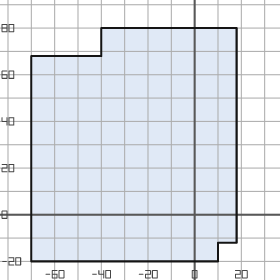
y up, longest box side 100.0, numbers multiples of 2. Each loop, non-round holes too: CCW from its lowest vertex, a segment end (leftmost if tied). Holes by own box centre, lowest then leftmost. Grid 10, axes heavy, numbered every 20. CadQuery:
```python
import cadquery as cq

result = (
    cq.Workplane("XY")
    .moveTo(-70.0, -20.0)
    .lineTo(10.0, -20.0)
    .lineTo(10.0, -12.0)
    .lineTo(18.0, -12.0)
    .lineTo(18.0, 80.0)
    .lineTo(-40.0, 80.0)
    .lineTo(-40.0, 68.0)
    .lineTo(-70.0, 68.0)
    .close()
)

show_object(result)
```